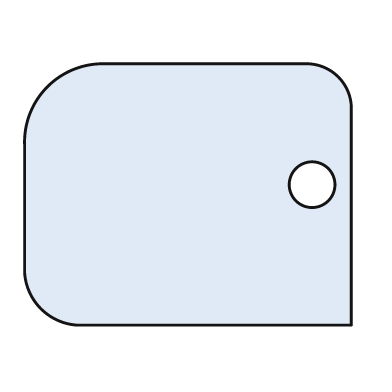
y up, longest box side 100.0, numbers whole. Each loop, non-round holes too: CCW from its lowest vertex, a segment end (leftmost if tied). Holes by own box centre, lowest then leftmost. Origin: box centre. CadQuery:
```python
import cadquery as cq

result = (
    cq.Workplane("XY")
    .moveTo(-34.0, -40.0)
    .lineTo(50.0, -40.0)
    .lineTo(50.0, 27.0)
    .threePointArc((46.0, 36.0), (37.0, 40.0))
    .lineTo(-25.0, 40.0)
    .threePointArc((-43.0, 33.0), (-50.0, 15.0))
    .lineTo(-50.0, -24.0)
    .threePointArc((-45.0, -35.0), (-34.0, -40.0))
    .close()
    .moveTo(38.0, 3.0)
    .circle(7.0)
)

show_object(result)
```